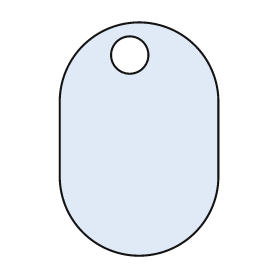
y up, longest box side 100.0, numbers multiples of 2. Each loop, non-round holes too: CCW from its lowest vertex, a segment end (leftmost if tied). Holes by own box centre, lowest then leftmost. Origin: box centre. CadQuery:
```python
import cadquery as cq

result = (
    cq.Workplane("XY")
    .moveTo(-34.0, -16.0)
    .threePointArc((0.0, -50.0), (34.0, -16.0))
    .lineTo(34.0, 16.0)
    .threePointArc((0.0, 50.0), (-34.0, 16.0))
    .close()
    .moveTo(-4.0, 36.0)
    .circle(8.0)
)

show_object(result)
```